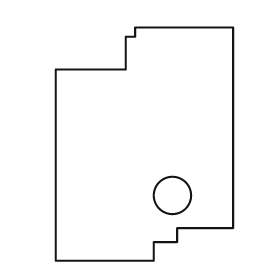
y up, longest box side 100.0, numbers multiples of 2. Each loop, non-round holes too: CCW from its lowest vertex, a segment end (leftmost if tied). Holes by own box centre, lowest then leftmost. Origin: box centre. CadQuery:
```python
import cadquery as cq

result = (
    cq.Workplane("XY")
    .moveTo(-38.0, -50.0)
    .lineTo(4.0, -50.0)
    .lineTo(4.0, -42.0)
    .lineTo(14.0, -42.0)
    .lineTo(14.0, -36.0)
    .lineTo(38.0, -36.0)
    .lineTo(38.0, 50.0)
    .lineTo(-4.0, 50.0)
    .lineTo(-4.0, 46.0)
    .lineTo(-8.0, 46.0)
    .lineTo(-8.0, 32.0)
    .lineTo(-38.0, 32.0)
    .close()
    .moveTo(12.0, -22.0)
    .circle(8.0)
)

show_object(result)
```